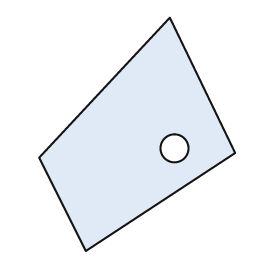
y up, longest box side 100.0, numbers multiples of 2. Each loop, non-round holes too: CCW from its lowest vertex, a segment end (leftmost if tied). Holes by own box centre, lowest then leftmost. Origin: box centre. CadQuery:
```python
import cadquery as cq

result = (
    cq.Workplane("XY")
    .moveTo(-22.0, -50.0)
    .lineTo(42.0, -8.0)
    .lineTo(14.0, 50.0)
    .lineTo(-42.0, -10.0)
    .close()
    .moveTo(16.0, -6.0)
    .circle(6.0)
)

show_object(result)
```